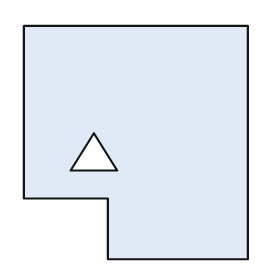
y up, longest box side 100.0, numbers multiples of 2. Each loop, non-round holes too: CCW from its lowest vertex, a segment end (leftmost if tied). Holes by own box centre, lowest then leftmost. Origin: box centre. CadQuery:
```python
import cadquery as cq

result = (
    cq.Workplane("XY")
    .moveTo(-12.0, -50.0)
    .lineTo(48.0, -50.0)
    .lineTo(48.0, 50.0)
    .lineTo(-48.0, 50.0)
    .lineTo(-48.0, -24.0)
    .lineTo(-12.0, -24.0)
    .close()
    .moveTo(-28.0, -12.0)
    .lineTo(-8.0, -12.0)
    .lineTo(-18.0, 4.0)
    .close()
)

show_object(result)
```